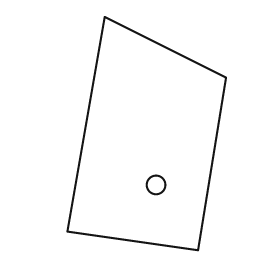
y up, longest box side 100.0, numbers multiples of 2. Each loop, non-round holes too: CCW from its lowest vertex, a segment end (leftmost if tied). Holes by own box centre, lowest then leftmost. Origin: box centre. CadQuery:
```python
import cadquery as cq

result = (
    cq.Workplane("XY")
    .moveTo(22.0, -50.0)
    .lineTo(34.0, 24.0)
    .lineTo(-18.0, 50.0)
    .lineTo(-34.0, -42.0)
    .close()
    .moveTo(4.0, -22.0)
    .circle(4.0)
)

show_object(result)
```